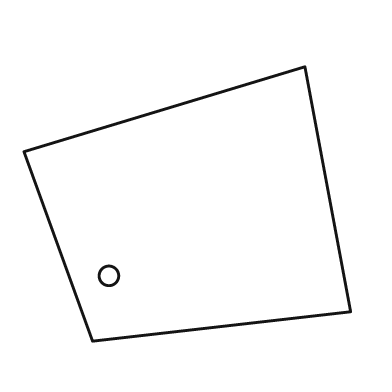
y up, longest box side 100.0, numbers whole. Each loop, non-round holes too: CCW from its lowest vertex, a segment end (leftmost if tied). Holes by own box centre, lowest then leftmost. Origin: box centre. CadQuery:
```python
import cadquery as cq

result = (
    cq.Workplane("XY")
    .moveTo(-29.0, -42.0)
    .lineTo(50.0, -33.0)
    .lineTo(36.0, 42.0)
    .lineTo(-50.0, 16.0)
    .close()
    .moveTo(-24.0, -22.0)
    .circle(3.0)
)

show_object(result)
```